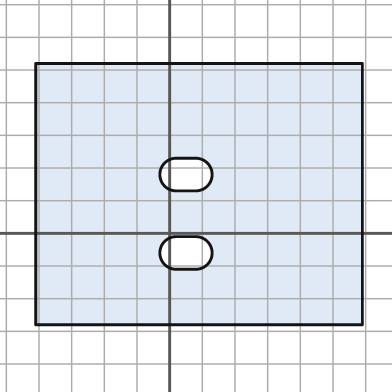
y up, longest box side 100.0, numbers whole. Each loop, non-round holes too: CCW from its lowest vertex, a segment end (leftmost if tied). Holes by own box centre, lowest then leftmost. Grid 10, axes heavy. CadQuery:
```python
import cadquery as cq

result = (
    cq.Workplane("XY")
    .moveTo(-41.0, -28.0)
    .lineTo(59.0, -28.0)
    .lineTo(59.0, 52.0)
    .lineTo(-41.0, 52.0)
    .close()
    .moveTo(2.0, -11.0)
    .lineTo(8.0, -11.0)
    .threePointArc((13.0, -6.0), (8.0, -1.0))
    .lineTo(2.0, -1.0)
    .threePointArc((-3.0, -6.0), (2.0, -11.0))
    .close()
    .moveTo(2.0, 13.0)
    .lineTo(8.0, 13.0)
    .threePointArc((13.0, 18.0), (8.0, 23.0))
    .lineTo(2.0, 23.0)
    .threePointArc((-3.0, 18.0), (2.0, 13.0))
    .close()
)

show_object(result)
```